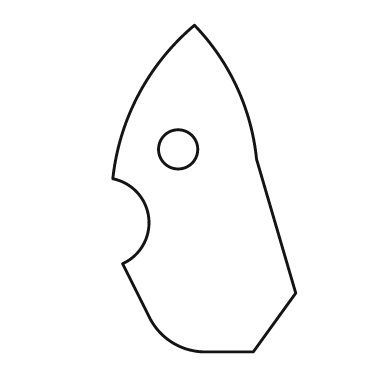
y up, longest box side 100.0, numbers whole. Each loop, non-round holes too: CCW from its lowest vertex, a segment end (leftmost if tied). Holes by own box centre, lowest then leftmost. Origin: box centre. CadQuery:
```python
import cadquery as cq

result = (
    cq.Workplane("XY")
    .moveTo(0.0, -50.0)
    .lineTo(15.0, -50.0)
    .lineTo(28.0, -32.0)
    .lineTo(16.0, 9.0)
    .threePointArc((10.0, 31.0), (-3.0, 50.0))
    .threePointArc((-20.0, 29.0), (-28.0, 3.0))
    .threePointArc((-17.0, -9.0), (-25.0, -23.0))
    .lineTo(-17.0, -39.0)
    .threePointArc((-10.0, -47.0), (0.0, -50.0))
    .close()
    .moveTo(-8.0, 12.0)
    .circle(6.0)
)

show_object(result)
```